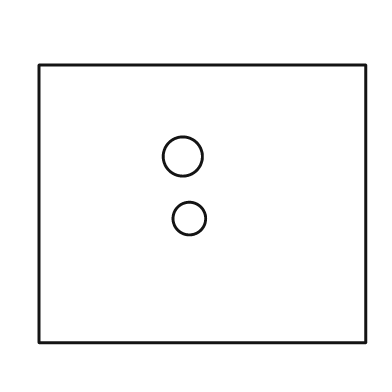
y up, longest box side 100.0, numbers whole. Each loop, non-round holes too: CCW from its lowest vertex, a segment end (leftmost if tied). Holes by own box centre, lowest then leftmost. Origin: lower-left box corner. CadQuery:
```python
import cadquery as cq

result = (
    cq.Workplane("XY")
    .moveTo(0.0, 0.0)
    .lineTo(100.0, 0.0)
    .lineTo(100.0, 85.0)
    .lineTo(0.0, 85.0)
    .close()
    .moveTo(46.0, 38.0)
    .circle(5.0)
    .moveTo(44.0, 57.0)
    .circle(6.0)
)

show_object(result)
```